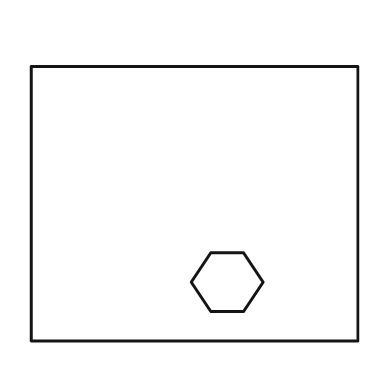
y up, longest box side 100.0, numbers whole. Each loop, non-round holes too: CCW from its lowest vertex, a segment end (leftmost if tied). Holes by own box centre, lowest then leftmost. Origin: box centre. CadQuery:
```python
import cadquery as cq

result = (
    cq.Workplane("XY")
    .moveTo(-50.0, -42.0)
    .lineTo(50.0, -42.0)
    .lineTo(50.0, 42.0)
    .lineTo(-50.0, 42.0)
    .close()
    .moveTo(5.0, -33.0)
    .lineTo(15.0, -33.0)
    .lineTo(21.0, -24.0)
    .lineTo(15.0, -15.0)
    .lineTo(5.0, -15.0)
    .lineTo(-1.0, -24.0)
    .close()
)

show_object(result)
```